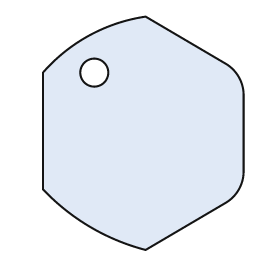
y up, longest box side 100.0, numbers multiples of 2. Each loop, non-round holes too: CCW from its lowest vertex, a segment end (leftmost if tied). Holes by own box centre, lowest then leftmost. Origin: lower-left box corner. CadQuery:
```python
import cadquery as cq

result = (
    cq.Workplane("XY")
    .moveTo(44.0, 0.0)
    .lineTo(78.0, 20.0)
    .threePointArc((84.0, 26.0), (86.0, 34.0))
    .lineTo(86.0, 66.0)
    .threePointArc((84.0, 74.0), (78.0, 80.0))
    .lineTo(44.0, 100.0)
    .threePointArc((20.0, 92.0), (0.0, 76.0))
    .lineTo(0.0, 26.0)
    .threePointArc((20.0, 10.0), (44.0, 0.0))
    .close()
    .moveTo(22.0, 76.0)
    .circle(6.0)
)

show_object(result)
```